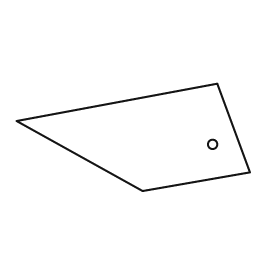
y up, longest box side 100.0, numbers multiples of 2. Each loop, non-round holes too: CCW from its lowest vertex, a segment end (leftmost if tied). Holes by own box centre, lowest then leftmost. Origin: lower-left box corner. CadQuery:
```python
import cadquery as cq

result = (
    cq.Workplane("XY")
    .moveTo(54.0, 0.0)
    .lineTo(100.0, 8.0)
    .lineTo(86.0, 46.0)
    .lineTo(0.0, 30.0)
    .close()
    .moveTo(84.0, 20.0)
    .circle(2.0)
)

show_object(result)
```